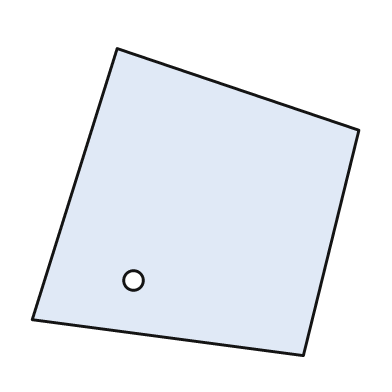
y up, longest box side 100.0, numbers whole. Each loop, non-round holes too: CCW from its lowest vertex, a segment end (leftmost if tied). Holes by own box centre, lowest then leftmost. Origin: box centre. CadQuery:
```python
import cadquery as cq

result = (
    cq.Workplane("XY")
    .moveTo(33.0, -47.0)
    .lineTo(50.0, 22.0)
    .lineTo(-24.0, 47.0)
    .lineTo(-50.0, -36.0)
    .close()
    .moveTo(-19.0, -24.0)
    .circle(3.0)
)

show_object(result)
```